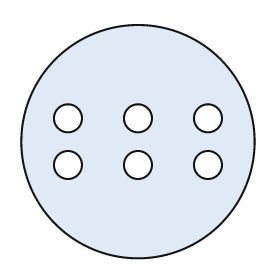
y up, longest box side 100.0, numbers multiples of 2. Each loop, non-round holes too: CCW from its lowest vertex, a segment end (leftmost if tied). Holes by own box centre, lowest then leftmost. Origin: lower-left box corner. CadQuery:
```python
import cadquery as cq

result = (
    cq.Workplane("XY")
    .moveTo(50.0, 50.0)
    .circle(50.0)
    .moveTo(20.0, 40.0)
    .circle(6.0)
    .moveTo(50.0, 40.0)
    .circle(6.0)
    .moveTo(80.0, 40.0)
    .circle(6.0)
    .moveTo(20.0, 60.0)
    .circle(6.0)
    .moveTo(50.0, 60.0)
    .circle(6.0)
    .moveTo(80.0, 60.0)
    .circle(6.0)
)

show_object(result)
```